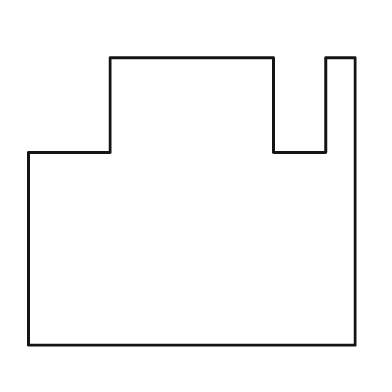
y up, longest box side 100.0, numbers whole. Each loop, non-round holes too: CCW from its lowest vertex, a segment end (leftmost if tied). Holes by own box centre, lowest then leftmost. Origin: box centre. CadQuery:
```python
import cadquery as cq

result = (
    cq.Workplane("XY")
    .moveTo(-50.0, -44.0)
    .lineTo(50.0, -44.0)
    .lineTo(50.0, 44.0)
    .lineTo(41.0, 44.0)
    .lineTo(41.0, 15.0)
    .lineTo(25.0, 15.0)
    .lineTo(25.0, 44.0)
    .lineTo(-25.0, 44.0)
    .lineTo(-25.0, 15.0)
    .lineTo(-50.0, 15.0)
    .close()
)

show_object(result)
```